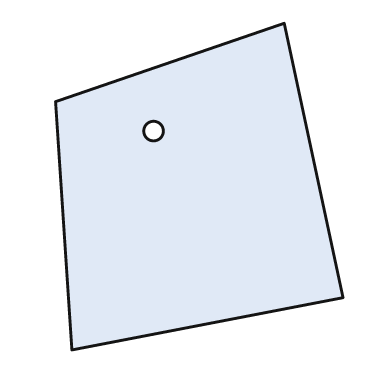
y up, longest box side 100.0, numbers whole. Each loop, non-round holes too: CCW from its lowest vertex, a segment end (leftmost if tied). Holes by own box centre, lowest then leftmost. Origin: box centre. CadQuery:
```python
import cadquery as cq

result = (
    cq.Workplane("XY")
    .moveTo(-39.0, -50.0)
    .lineTo(44.0, -34.0)
    .lineTo(26.0, 50.0)
    .lineTo(-44.0, 26.0)
    .close()
    .moveTo(-14.0, 17.0)
    .circle(3.0)
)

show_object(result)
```